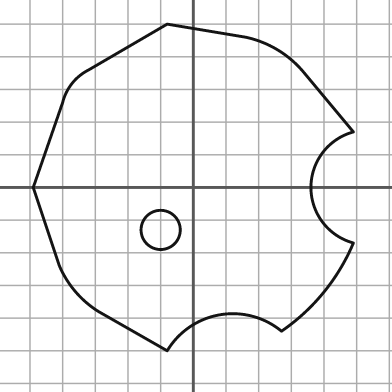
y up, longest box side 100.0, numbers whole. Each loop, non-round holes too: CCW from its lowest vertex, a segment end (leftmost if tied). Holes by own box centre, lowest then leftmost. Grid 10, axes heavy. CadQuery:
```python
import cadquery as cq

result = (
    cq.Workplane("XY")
    .moveTo(-8.0, -50.0)
    .threePointArc((8.0, -39.0), (27.0, -44.0))
    .threePointArc((40.0, -32.0), (49.0, -17.0))
    .threePointArc((36.0, 0.0), (49.0, 17.0))
    .lineTo(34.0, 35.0)
    .threePointArc((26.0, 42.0), (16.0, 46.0))
    .lineTo(-8.0, 50.0)
    .lineTo(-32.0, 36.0)
    .threePointArc((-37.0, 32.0), (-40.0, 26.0))
    .lineTo(-49.0, 0.0)
    .lineTo(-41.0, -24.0)
    .threePointArc((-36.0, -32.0), (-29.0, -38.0))
    .close()
    .moveTo(-10.0, -13.0)
    .circle(6.0)
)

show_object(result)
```